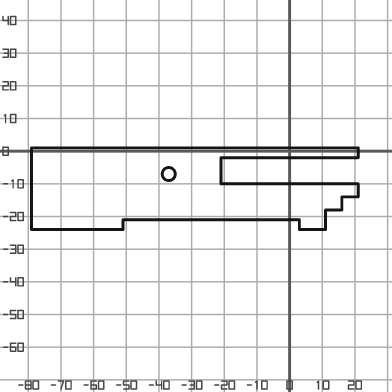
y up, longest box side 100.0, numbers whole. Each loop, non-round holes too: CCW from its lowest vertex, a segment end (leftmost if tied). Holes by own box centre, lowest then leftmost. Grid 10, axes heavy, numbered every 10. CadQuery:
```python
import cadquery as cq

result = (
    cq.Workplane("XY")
    .moveTo(-79.0, -24.0)
    .lineTo(-51.0, -24.0)
    .lineTo(-51.0, -21.0)
    .lineTo(3.0, -21.0)
    .lineTo(3.0, -24.0)
    .lineTo(11.0, -24.0)
    .lineTo(11.0, -18.0)
    .lineTo(16.0, -18.0)
    .lineTo(16.0, -14.0)
    .lineTo(21.0, -14.0)
    .lineTo(21.0, -10.0)
    .lineTo(-21.0, -10.0)
    .lineTo(-21.0, -2.0)
    .lineTo(21.0, -2.0)
    .lineTo(21.0, 1.0)
    .lineTo(-79.0, 1.0)
    .close()
    .moveTo(-37.0, -7.0)
    .circle(2.0)
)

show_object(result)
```